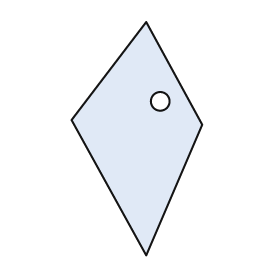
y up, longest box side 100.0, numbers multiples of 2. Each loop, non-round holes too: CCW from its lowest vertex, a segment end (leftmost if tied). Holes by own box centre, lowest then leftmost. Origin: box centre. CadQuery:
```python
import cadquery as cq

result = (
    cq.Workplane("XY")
    .moveTo(4.0, -50.0)
    .lineTo(28.0, 6.0)
    .lineTo(4.0, 50.0)
    .lineTo(-28.0, 8.0)
    .close()
    .moveTo(10.0, 16.0)
    .circle(4.0)
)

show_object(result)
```